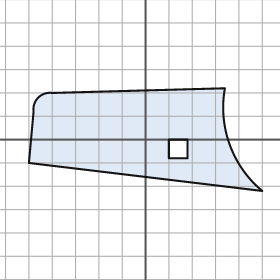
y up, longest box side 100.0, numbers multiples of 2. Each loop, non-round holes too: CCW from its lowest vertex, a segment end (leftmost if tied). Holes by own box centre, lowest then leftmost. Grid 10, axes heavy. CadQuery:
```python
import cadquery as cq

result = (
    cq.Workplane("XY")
    .moveTo(50.0, -22.0)
    .threePointArc((36.0, -2.0), (34.0, 22.0))
    .lineTo(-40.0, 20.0)
    .threePointArc((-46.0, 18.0), (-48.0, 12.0))
    .lineTo(-50.0, -10.0)
    .close()
    .moveTo(10.0, -8.0)
    .lineTo(18.0, -8.0)
    .lineTo(18.0, 0.0)
    .lineTo(10.0, 0.0)
    .close()
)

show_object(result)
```